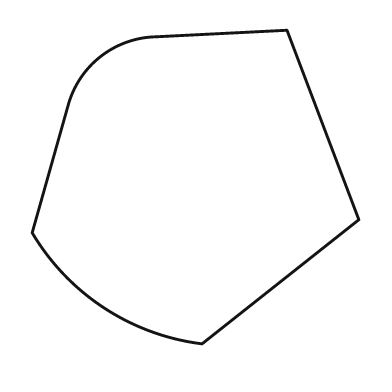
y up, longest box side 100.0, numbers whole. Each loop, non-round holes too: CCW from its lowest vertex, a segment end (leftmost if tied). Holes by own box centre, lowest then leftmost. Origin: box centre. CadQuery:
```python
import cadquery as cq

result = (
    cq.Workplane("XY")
    .moveTo(2.0, -48.0)
    .lineTo(50.0, -10.0)
    .lineTo(28.0, 48.0)
    .lineTo(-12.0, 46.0)
    .threePointArc((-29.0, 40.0), (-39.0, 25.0))
    .lineTo(-50.0, -14.0)
    .threePointArc((-28.0, -37.0), (2.0, -48.0))
    .close()
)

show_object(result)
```